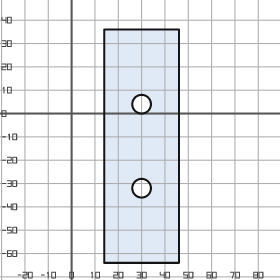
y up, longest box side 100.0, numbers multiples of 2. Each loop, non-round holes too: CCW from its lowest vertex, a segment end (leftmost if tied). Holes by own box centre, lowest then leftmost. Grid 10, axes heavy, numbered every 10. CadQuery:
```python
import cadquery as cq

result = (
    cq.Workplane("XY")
    .moveTo(14.0, -64.0)
    .lineTo(46.0, -64.0)
    .lineTo(46.0, 36.0)
    .lineTo(14.0, 36.0)
    .close()
    .moveTo(30.0, -32.0)
    .circle(4.0)
    .moveTo(30.0, 4.0)
    .circle(4.0)
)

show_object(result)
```